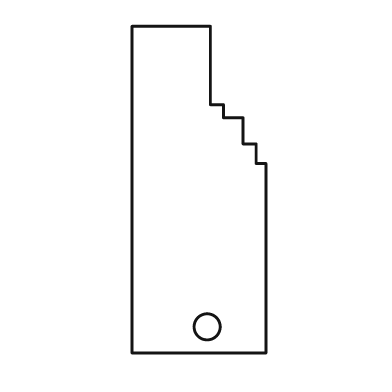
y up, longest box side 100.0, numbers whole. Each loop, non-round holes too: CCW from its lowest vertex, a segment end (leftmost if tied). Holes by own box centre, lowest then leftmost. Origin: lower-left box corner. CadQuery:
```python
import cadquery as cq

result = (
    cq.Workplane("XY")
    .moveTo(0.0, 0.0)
    .lineTo(41.0, 0.0)
    .lineTo(41.0, 58.0)
    .lineTo(38.0, 58.0)
    .lineTo(38.0, 64.0)
    .lineTo(34.0, 64.0)
    .lineTo(34.0, 72.0)
    .lineTo(28.0, 72.0)
    .lineTo(28.0, 76.0)
    .lineTo(24.0, 76.0)
    .lineTo(24.0, 100.0)
    .lineTo(0.0, 100.0)
    .close()
    .moveTo(23.0, 8.0)
    .circle(4.0)
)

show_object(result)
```